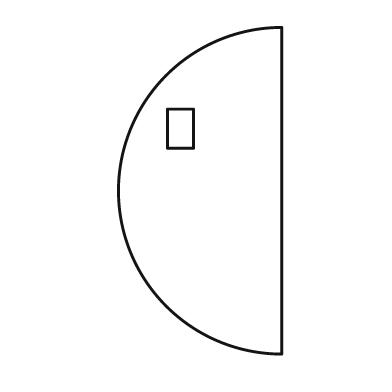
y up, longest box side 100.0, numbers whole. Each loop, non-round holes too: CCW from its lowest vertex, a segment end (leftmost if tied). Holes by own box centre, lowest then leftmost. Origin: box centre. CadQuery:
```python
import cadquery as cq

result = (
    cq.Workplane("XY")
    .moveTo(25.0, -50.0)
    .lineTo(25.0, 50.0)
    .threePointArc((-25.0, 0.0), (25.0, -50.0))
    .close()
    .moveTo(-10.0, 13.0)
    .lineTo(-2.0, 13.0)
    .lineTo(-2.0, 25.0)
    .lineTo(-10.0, 25.0)
    .close()
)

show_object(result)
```